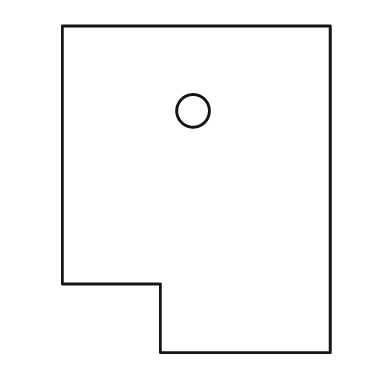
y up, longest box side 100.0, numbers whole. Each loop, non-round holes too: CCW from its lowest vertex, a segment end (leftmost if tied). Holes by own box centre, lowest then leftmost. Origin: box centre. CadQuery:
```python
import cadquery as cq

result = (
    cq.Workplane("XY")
    .moveTo(-11.0, -50.0)
    .lineTo(41.0, -50.0)
    .lineTo(41.0, 50.0)
    .lineTo(-41.0, 50.0)
    .lineTo(-41.0, -29.0)
    .lineTo(-11.0, -29.0)
    .close()
    .moveTo(-1.0, 24.0)
    .circle(5.0)
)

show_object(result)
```